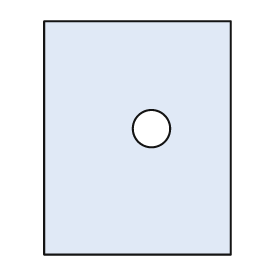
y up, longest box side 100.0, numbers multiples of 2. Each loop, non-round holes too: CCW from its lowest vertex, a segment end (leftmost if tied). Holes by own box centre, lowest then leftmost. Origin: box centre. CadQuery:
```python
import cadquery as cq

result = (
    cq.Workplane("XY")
    .moveTo(-40.0, -50.0)
    .lineTo(40.0, -50.0)
    .lineTo(40.0, 50.0)
    .lineTo(-40.0, 50.0)
    .close()
    .moveTo(6.0, 4.0)
    .circle(8.0)
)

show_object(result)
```